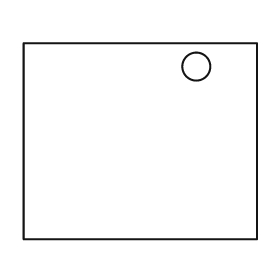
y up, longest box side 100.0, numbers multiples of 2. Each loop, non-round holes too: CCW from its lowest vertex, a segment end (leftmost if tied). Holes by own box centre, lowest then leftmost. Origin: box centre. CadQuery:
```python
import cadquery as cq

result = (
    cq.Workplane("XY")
    .moveTo(-50.0, -42.0)
    .lineTo(50.0, -42.0)
    .lineTo(50.0, 42.0)
    .lineTo(-50.0, 42.0)
    .close()
    .moveTo(24.0, 32.0)
    .circle(6.0)
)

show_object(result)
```